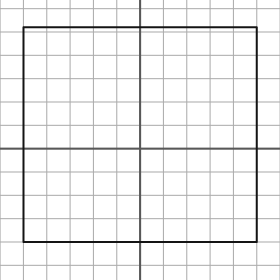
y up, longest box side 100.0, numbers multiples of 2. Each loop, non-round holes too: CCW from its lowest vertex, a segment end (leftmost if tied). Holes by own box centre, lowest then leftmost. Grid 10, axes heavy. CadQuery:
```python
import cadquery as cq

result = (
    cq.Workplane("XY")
    .moveTo(-50.0, -40.0)
    .lineTo(50.0, -40.0)
    .lineTo(50.0, 52.0)
    .lineTo(-50.0, 52.0)
    .close()
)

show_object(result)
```